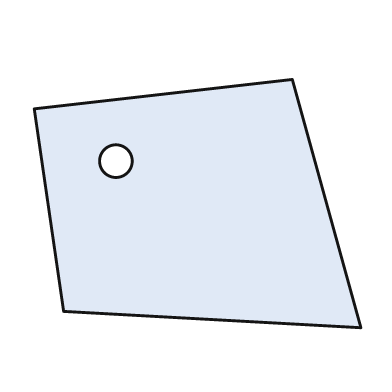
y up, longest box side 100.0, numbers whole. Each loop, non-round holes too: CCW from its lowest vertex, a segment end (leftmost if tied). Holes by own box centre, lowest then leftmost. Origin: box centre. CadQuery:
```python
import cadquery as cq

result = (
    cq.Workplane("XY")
    .moveTo(50.0, -38.0)
    .lineTo(29.0, 38.0)
    .lineTo(-50.0, 29.0)
    .lineTo(-41.0, -33.0)
    .close()
    .moveTo(-25.0, 13.0)
    .circle(5.0)
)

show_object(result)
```